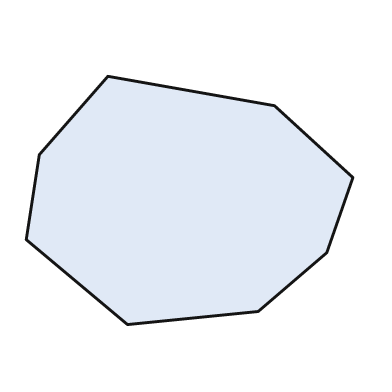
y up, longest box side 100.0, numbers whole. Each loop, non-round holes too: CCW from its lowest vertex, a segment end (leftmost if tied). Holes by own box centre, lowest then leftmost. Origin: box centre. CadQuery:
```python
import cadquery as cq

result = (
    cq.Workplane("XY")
    .moveTo(-19.0, -38.0)
    .lineTo(21.0, -34.0)
    .lineTo(42.0, -16.0)
    .lineTo(50.0, 7.0)
    .lineTo(26.0, 29.0)
    .lineTo(-25.0, 38.0)
    .lineTo(-46.0, 14.0)
    .lineTo(-50.0, -12.0)
    .close()
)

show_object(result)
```